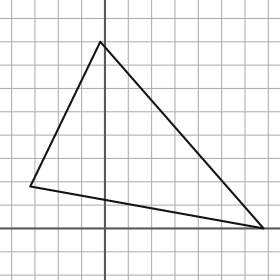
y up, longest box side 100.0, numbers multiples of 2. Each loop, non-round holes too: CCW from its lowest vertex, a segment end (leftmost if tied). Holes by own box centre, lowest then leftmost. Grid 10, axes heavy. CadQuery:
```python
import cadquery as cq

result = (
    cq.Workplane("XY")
    .moveTo(68.0, 0.0)
    .lineTo(-2.0, 80.0)
    .lineTo(-32.0, 18.0)
    .close()
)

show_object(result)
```